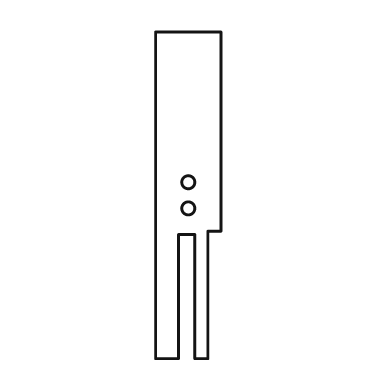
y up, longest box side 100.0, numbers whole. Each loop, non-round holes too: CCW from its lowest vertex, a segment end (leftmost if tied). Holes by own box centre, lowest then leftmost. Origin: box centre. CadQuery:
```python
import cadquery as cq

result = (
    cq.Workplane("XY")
    .moveTo(-10.0, -50.0)
    .lineTo(-3.0, -50.0)
    .lineTo(-3.0, -12.0)
    .lineTo(2.0, -12.0)
    .lineTo(2.0, -50.0)
    .lineTo(6.0, -50.0)
    .lineTo(6.0, -11.0)
    .lineTo(10.0, -11.0)
    .lineTo(10.0, 50.0)
    .lineTo(-10.0, 50.0)
    .close()
    .moveTo(0.0, -4.0)
    .circle(2.0)
    .moveTo(0.0, 4.0)
    .circle(2.0)
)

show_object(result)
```